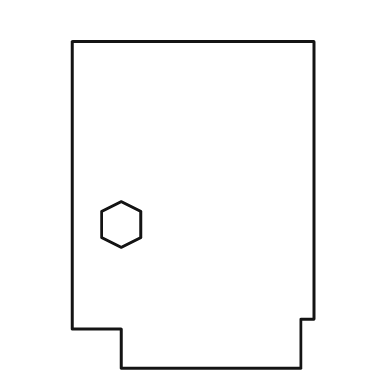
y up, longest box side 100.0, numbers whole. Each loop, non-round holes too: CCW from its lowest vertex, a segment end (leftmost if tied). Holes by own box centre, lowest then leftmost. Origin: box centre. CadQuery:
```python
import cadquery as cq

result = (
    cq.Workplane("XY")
    .moveTo(-22.0, -50.0)
    .lineTo(33.0, -50.0)
    .lineTo(33.0, -35.0)
    .lineTo(37.0, -35.0)
    .lineTo(37.0, 50.0)
    .lineTo(-37.0, 50.0)
    .lineTo(-37.0, -38.0)
    .lineTo(-22.0, -38.0)
    .close()
    .moveTo(-22.0, -13.0)
    .lineTo(-16.0, -10.0)
    .lineTo(-16.0, -2.0)
    .lineTo(-22.0, 1.0)
    .lineTo(-28.0, -2.0)
    .lineTo(-28.0, -10.0)
    .close()
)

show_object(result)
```